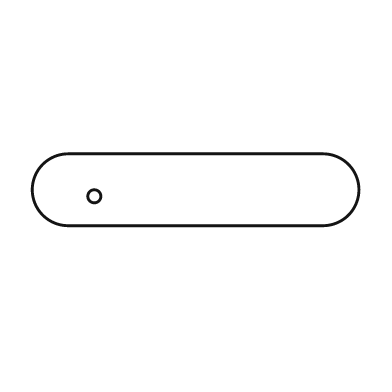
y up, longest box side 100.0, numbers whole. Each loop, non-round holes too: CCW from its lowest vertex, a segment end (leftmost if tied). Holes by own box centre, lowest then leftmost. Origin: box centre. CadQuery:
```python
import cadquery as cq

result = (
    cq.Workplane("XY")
    .moveTo(-39.0, -11.0)
    .lineTo(39.0, -11.0)
    .threePointArc((50.0, 0.0), (39.0, 11.0))
    .lineTo(-39.0, 11.0)
    .threePointArc((-50.0, 0.0), (-39.0, -11.0))
    .close()
    .moveTo(-31.0, -2.0)
    .circle(2.0)
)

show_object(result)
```